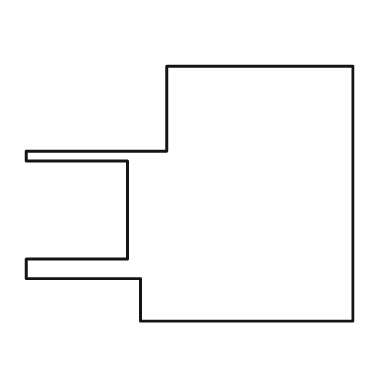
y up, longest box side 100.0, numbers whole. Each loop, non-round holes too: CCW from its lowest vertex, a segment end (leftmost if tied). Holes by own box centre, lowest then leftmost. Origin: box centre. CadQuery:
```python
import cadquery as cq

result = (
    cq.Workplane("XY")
    .moveTo(-15.0, -39.0)
    .lineTo(50.0, -39.0)
    .lineTo(50.0, 39.0)
    .lineTo(-7.0, 39.0)
    .lineTo(-7.0, 13.0)
    .lineTo(-50.0, 13.0)
    .lineTo(-50.0, 10.0)
    .lineTo(-19.0, 10.0)
    .lineTo(-19.0, -20.0)
    .lineTo(-50.0, -20.0)
    .lineTo(-50.0, -26.0)
    .lineTo(-15.0, -26.0)
    .close()
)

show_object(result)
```